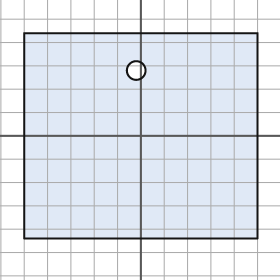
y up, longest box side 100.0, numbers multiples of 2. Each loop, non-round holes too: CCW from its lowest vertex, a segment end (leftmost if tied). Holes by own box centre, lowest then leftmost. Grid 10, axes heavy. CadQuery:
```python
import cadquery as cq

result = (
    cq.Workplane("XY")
    .moveTo(-50.0, -44.0)
    .lineTo(50.0, -44.0)
    .lineTo(50.0, 44.0)
    .lineTo(-50.0, 44.0)
    .close()
    .moveTo(-2.0, 28.0)
    .circle(4.0)
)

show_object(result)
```